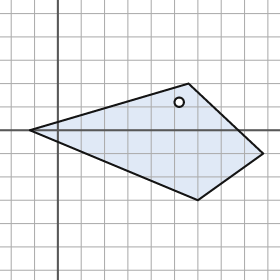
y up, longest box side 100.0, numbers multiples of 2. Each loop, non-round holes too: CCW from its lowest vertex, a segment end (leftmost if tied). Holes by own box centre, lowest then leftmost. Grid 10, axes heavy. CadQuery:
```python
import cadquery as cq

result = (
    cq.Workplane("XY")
    .moveTo(60.0, -30.0)
    .lineTo(88.0, -10.0)
    .lineTo(56.0, 20.0)
    .lineTo(-12.0, 0.0)
    .close()
    .moveTo(52.0, 12.0)
    .circle(2.0)
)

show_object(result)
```